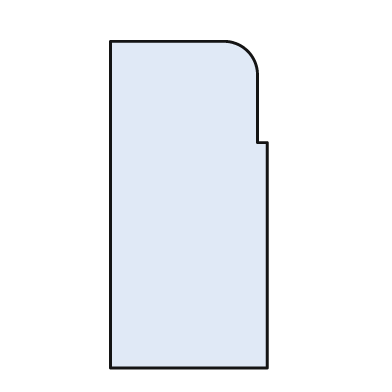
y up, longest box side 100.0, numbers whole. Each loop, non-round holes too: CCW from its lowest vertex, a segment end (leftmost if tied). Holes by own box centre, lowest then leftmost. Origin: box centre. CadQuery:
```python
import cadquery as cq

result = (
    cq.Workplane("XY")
    .moveTo(-24.0, -50.0)
    .lineTo(24.0, -50.0)
    .lineTo(24.0, 19.0)
    .lineTo(21.0, 19.0)
    .lineTo(21.0, 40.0)
    .threePointArc((18.0, 47.0), (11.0, 50.0))
    .lineTo(-24.0, 50.0)
    .close()
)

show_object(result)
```